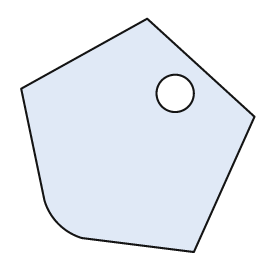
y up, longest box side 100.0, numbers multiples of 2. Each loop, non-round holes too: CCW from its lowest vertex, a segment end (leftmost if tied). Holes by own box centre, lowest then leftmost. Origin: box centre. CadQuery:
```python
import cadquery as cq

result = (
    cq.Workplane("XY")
    .moveTo(24.0, -50.0)
    .lineTo(50.0, 8.0)
    .lineTo(4.0, 50.0)
    .lineTo(-50.0, 20.0)
    .lineTo(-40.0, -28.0)
    .threePointArc((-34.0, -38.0), (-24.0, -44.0))
    .close()
    .moveTo(16.0, 18.0)
    .circle(8.0)
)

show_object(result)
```